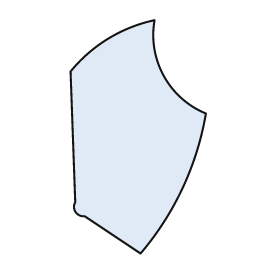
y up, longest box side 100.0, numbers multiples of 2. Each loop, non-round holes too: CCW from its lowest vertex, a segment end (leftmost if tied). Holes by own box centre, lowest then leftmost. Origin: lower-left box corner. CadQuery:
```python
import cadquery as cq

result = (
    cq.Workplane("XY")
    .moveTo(30.0, 0.0)
    .threePointArc((48.0, 28.0), (58.0, 60.0))
    .threePointArc((40.0, 76.0), (36.0, 100.0))
    .threePointArc((16.0, 92.0), (0.0, 78.0))
    .lineTo(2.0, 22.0)
    .threePointArc((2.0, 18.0), (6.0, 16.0))
    .close()
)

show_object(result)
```